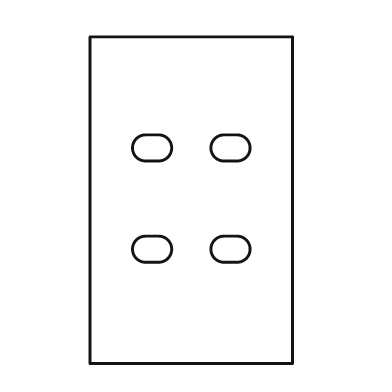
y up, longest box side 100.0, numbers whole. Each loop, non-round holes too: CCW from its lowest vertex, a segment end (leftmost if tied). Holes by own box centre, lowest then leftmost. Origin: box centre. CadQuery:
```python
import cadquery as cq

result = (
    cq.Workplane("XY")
    .moveTo(-31.0, -50.0)
    .lineTo(31.0, -50.0)
    .lineTo(31.0, 50.0)
    .lineTo(-31.0, 50.0)
    .close()
    .moveTo(-14.0, -19.0)
    .lineTo(-10.0, -19.0)
    .threePointArc((-6.0, -15.0), (-10.0, -11.0))
    .lineTo(-14.0, -11.0)
    .threePointArc((-18.0, -15.0), (-14.0, -19.0))
    .close()
    .moveTo(10.0, -19.0)
    .lineTo(14.0, -19.0)
    .threePointArc((18.0, -15.0), (14.0, -11.0))
    .lineTo(10.0, -11.0)
    .threePointArc((6.0, -15.0), (10.0, -19.0))
    .close()
    .moveTo(-14.0, 12.0)
    .lineTo(-10.0, 12.0)
    .threePointArc((-6.0, 16.0), (-10.0, 20.0))
    .lineTo(-14.0, 20.0)
    .threePointArc((-18.0, 16.0), (-14.0, 12.0))
    .close()
    .moveTo(10.0, 12.0)
    .lineTo(14.0, 12.0)
    .threePointArc((18.0, 16.0), (14.0, 20.0))
    .lineTo(10.0, 20.0)
    .threePointArc((6.0, 16.0), (10.0, 12.0))
    .close()
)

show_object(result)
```